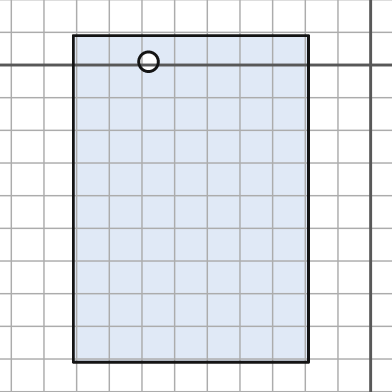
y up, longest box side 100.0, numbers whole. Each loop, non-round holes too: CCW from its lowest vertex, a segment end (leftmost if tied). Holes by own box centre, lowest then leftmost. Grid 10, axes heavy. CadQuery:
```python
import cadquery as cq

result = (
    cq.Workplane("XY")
    .moveTo(-91.0, -91.0)
    .lineTo(-19.0, -91.0)
    .lineTo(-19.0, 9.0)
    .lineTo(-91.0, 9.0)
    .close()
    .moveTo(-68.0, 1.0)
    .circle(3.0)
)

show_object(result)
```